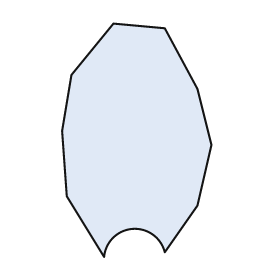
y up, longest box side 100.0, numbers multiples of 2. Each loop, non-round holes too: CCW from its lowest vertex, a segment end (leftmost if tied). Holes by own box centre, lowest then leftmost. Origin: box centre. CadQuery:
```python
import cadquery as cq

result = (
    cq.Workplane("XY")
    .moveTo(-14.0, -50.0)
    .threePointArc((-2.0, -38.0), (12.0, -48.0))
    .lineTo(26.0, -28.0)
    .lineTo(32.0, -2.0)
    .lineTo(26.0, 22.0)
    .lineTo(12.0, 48.0)
    .lineTo(-10.0, 50.0)
    .lineTo(-28.0, 28.0)
    .lineTo(-32.0, 4.0)
    .lineTo(-30.0, -24.0)
    .close()
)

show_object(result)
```